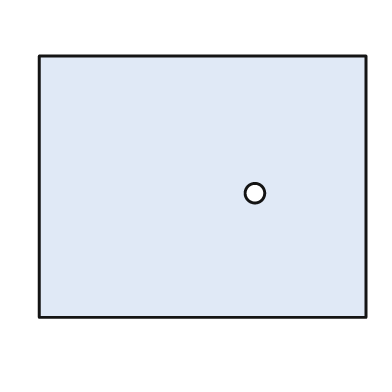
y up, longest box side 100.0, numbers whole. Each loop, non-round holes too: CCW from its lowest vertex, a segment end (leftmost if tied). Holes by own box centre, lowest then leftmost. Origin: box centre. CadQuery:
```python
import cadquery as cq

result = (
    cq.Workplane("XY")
    .moveTo(-50.0, -40.0)
    .lineTo(50.0, -40.0)
    .lineTo(50.0, 40.0)
    .lineTo(-50.0, 40.0)
    .close()
    .moveTo(16.0, -2.0)
    .circle(3.0)
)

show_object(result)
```